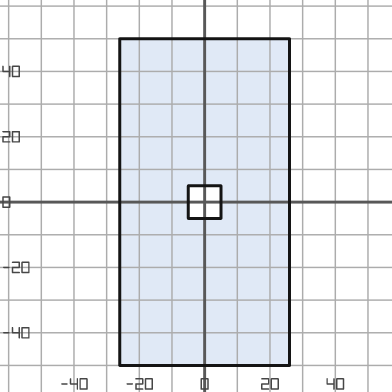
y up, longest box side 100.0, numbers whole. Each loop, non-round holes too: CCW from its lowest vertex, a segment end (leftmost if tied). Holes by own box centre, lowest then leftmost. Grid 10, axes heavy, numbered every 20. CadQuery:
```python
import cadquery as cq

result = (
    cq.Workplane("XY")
    .moveTo(-26.0, -50.0)
    .lineTo(26.0, -50.0)
    .lineTo(26.0, 50.0)
    .lineTo(-26.0, 50.0)
    .close()
    .moveTo(-5.0, -5.0)
    .lineTo(5.0, -5.0)
    .lineTo(5.0, 5.0)
    .lineTo(-5.0, 5.0)
    .close()
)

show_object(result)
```